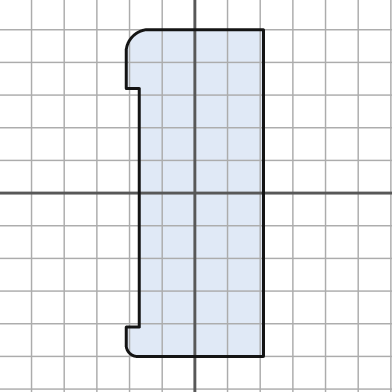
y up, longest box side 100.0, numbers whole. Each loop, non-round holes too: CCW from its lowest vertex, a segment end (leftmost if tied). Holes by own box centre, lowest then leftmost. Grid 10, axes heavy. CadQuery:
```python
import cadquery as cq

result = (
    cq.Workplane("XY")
    .moveTo(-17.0, -50.0)
    .lineTo(21.0, -50.0)
    .lineTo(21.0, 50.0)
    .lineTo(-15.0, 50.0)
    .threePointArc((-19.0, 48.0), (-21.0, 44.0))
    .lineTo(-21.0, 32.0)
    .lineTo(-17.0, 32.0)
    .lineTo(-17.0, -41.0)
    .lineTo(-21.0, -41.0)
    .lineTo(-21.0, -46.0)
    .threePointArc((-20.0, -49.0), (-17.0, -50.0))
    .close()
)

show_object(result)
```